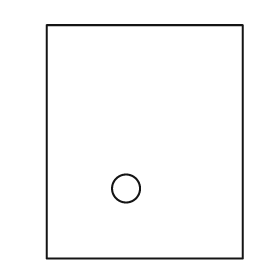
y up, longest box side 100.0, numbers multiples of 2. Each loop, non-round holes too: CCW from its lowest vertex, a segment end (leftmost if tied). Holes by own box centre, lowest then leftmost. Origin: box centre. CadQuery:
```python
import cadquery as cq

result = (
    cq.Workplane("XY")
    .moveTo(-42.0, -50.0)
    .lineTo(42.0, -50.0)
    .lineTo(42.0, 50.0)
    .lineTo(-42.0, 50.0)
    .close()
    .moveTo(-8.0, -20.0)
    .circle(6.0)
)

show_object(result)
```